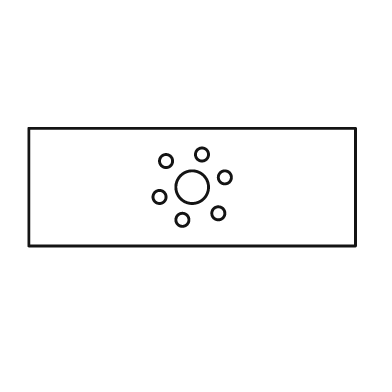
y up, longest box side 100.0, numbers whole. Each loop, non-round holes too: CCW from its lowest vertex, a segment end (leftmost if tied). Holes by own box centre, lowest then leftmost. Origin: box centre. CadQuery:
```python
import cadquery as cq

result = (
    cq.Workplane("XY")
    .moveTo(-50.0, -18.0)
    .lineTo(50.0, -18.0)
    .lineTo(50.0, 18.0)
    .lineTo(-50.0, 18.0)
    .close()
    .moveTo(-3.0, -10.0)
    .circle(2.0)
    .moveTo(8.0, -8.0)
    .circle(2.0)
    .moveTo(-10.0, -3.0)
    .circle(2.0)
    .moveTo(0.0, 0.0)
    .circle(5.0)
    .moveTo(10.0, 3.0)
    .circle(2.0)
    .moveTo(-8.0, 8.0)
    .circle(2.0)
    .moveTo(3.0, 10.0)
    .circle(2.0)
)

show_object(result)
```